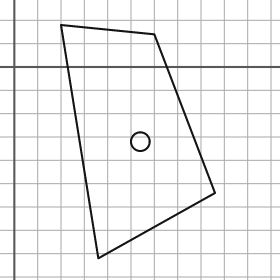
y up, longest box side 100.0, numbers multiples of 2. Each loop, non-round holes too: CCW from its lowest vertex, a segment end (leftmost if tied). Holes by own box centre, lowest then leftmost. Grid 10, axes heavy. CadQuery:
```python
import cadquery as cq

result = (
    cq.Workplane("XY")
    .moveTo(36.0, -82.0)
    .lineTo(86.0, -54.0)
    .lineTo(60.0, 14.0)
    .lineTo(20.0, 18.0)
    .close()
    .moveTo(54.0, -32.0)
    .circle(4.0)
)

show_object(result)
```